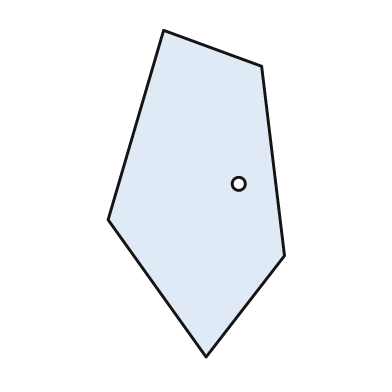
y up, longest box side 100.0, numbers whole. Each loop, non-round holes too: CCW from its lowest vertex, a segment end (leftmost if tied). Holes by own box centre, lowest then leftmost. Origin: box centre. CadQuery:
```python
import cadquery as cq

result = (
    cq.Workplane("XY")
    .moveTo(3.0, -50.0)
    .lineTo(27.0, -19.0)
    .lineTo(20.0, 39.0)
    .lineTo(-10.0, 50.0)
    .lineTo(-27.0, -8.0)
    .close()
    .moveTo(13.0, 3.0)
    .circle(2.0)
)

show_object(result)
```